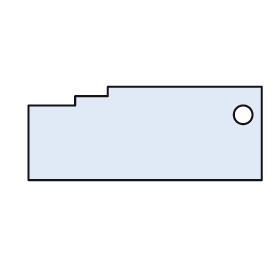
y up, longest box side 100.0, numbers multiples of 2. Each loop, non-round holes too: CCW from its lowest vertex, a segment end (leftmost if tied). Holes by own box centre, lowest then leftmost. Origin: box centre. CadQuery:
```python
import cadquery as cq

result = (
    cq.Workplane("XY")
    .moveTo(-50.0, -20.0)
    .lineTo(50.0, -20.0)
    .lineTo(50.0, 20.0)
    .lineTo(-16.0, 20.0)
    .lineTo(-16.0, 16.0)
    .lineTo(-30.0, 16.0)
    .lineTo(-30.0, 12.0)
    .lineTo(-50.0, 12.0)
    .close()
    .moveTo(42.0, 8.0)
    .circle(4.0)
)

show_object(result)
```